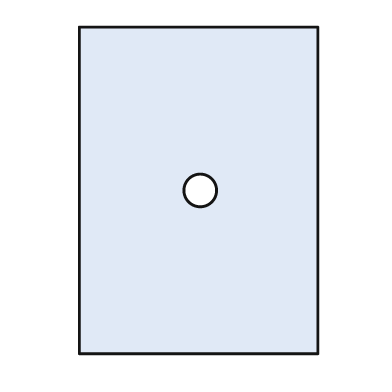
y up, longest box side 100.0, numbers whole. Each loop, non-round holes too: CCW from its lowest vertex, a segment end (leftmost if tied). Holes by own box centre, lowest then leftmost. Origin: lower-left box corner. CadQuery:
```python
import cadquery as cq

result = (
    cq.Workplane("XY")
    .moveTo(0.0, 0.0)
    .lineTo(73.0, 0.0)
    .lineTo(73.0, 100.0)
    .lineTo(0.0, 100.0)
    .close()
    .moveTo(37.0, 50.0)
    .circle(5.0)
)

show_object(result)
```